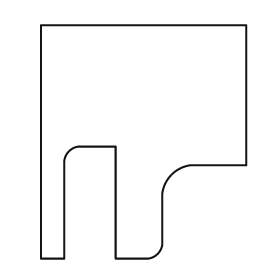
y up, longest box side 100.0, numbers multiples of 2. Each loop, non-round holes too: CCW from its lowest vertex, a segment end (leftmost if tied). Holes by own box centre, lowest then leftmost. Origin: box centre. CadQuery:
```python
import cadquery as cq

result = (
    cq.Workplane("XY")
    .moveTo(-44.0, -50.0)
    .lineTo(-34.0, -50.0)
    .lineTo(-34.0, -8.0)
    .threePointArc((-32.0, -4.0), (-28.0, -2.0))
    .lineTo(-12.0, -2.0)
    .lineTo(-12.0, -50.0)
    .lineTo(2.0, -50.0)
    .threePointArc((6.0, -48.0), (8.0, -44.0))
    .lineTo(8.0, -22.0)
    .threePointArc((12.0, -14.0), (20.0, -10.0))
    .lineTo(44.0, -10.0)
    .lineTo(44.0, 50.0)
    .lineTo(-44.0, 50.0)
    .close()
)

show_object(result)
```